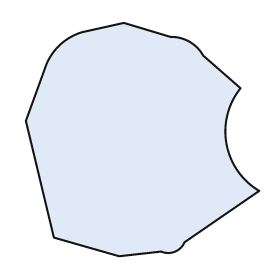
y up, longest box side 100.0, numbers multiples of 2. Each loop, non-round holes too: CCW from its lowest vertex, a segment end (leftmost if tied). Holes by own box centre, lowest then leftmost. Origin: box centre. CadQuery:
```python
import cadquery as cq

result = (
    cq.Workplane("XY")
    .moveTo(-10.0, -50.0)
    .lineTo(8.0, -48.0)
    .threePointArc((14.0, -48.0), (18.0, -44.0))
    .lineTo(50.0, -22.0)
    .threePointArc((36.0, -2.0), (42.0, 22.0))
    .lineTo(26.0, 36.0)
    .threePointArc((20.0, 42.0), (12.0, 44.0))
    .lineTo(-8.0, 50.0)
    .lineTo(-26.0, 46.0)
    .threePointArc((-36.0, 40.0), (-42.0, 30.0))
    .lineTo(-50.0, 8.0)
    .lineTo(-38.0, -42.0)
    .close()
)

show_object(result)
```